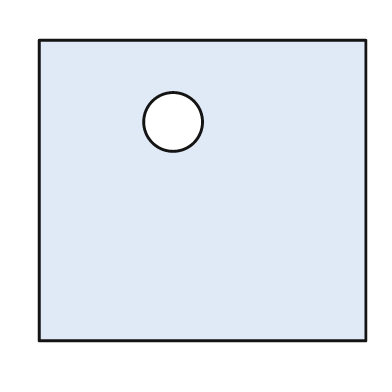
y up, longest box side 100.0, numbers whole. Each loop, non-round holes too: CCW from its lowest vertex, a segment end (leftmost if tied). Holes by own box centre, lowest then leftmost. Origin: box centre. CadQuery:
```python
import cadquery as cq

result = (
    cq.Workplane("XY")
    .moveTo(-50.0, -46.0)
    .lineTo(50.0, -46.0)
    .lineTo(50.0, 46.0)
    .lineTo(-50.0, 46.0)
    .close()
    .moveTo(-9.0, 21.0)
    .circle(9.0)
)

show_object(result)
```